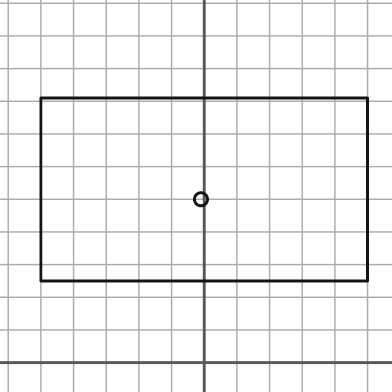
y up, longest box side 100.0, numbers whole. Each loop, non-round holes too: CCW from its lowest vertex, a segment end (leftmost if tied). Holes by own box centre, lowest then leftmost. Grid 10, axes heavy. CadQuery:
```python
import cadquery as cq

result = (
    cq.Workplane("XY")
    .moveTo(-50.0, 25.0)
    .lineTo(50.0, 25.0)
    .lineTo(50.0, 81.0)
    .lineTo(-50.0, 81.0)
    .close()
    .moveTo(-1.0, 50.0)
    .circle(2.0)
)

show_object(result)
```